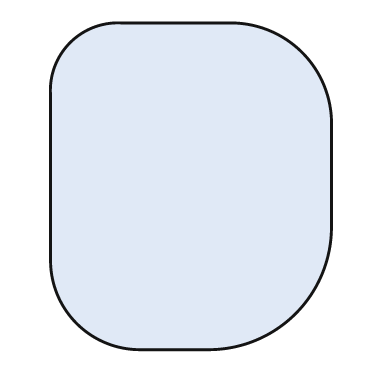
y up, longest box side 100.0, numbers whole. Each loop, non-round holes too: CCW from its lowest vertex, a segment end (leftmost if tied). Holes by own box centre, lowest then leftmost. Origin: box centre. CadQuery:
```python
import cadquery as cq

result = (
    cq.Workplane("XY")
    .moveTo(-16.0, -50.0)
    .lineTo(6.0, -50.0)
    .threePointArc((32.0, -39.0), (43.0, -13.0))
    .lineTo(43.0, 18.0)
    .threePointArc((34.0, 41.0), (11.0, 50.0))
    .lineTo(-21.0, 50.0)
    .threePointArc((-37.0, 44.0), (-43.0, 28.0))
    .lineTo(-43.0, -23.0)
    .threePointArc((-35.0, -42.0), (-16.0, -50.0))
    .close()
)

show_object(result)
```